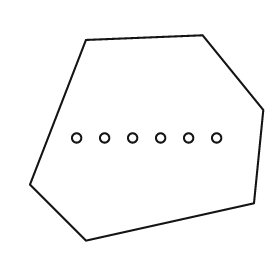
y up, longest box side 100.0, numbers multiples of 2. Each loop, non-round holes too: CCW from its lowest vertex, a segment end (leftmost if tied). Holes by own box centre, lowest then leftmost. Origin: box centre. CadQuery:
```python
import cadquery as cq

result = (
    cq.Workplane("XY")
    .moveTo(-26.0, -44.0)
    .lineTo(46.0, -28.0)
    .lineTo(50.0, 12.0)
    .lineTo(24.0, 44.0)
    .lineTo(-26.0, 42.0)
    .lineTo(-50.0, -20.0)
    .close()
    .moveTo(-30.0, 0.0)
    .circle(2.0)
    .moveTo(-18.0, 0.0)
    .circle(2.0)
    .moveTo(-6.0, 0.0)
    .circle(2.0)
    .moveTo(6.0, 0.0)
    .circle(2.0)
    .moveTo(18.0, 0.0)
    .circle(2.0)
    .moveTo(30.0, 0.0)
    .circle(2.0)
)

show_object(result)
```